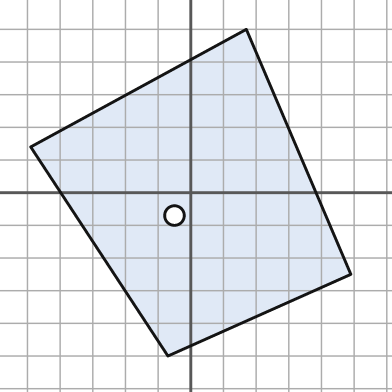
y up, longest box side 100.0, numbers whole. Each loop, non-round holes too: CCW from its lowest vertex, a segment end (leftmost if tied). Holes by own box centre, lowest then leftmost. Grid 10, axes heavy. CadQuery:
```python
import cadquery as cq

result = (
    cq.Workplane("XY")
    .moveTo(-7.0, -50.0)
    .lineTo(49.0, -25.0)
    .lineTo(17.0, 50.0)
    .lineTo(-49.0, 14.0)
    .close()
    .moveTo(-5.0, -7.0)
    .circle(3.0)
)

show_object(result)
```